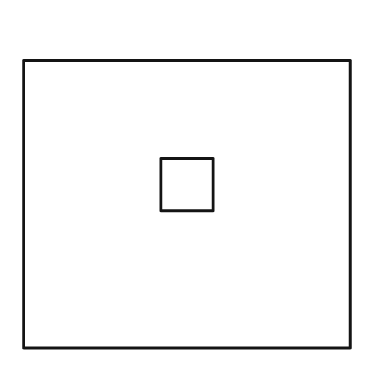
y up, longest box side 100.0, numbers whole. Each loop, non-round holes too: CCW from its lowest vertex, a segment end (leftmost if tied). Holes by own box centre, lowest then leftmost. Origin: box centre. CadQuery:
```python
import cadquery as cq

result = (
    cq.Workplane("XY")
    .moveTo(-50.0, -44.0)
    .lineTo(50.0, -44.0)
    .lineTo(50.0, 44.0)
    .lineTo(-50.0, 44.0)
    .close()
    .moveTo(-8.0, -2.0)
    .lineTo(8.0, -2.0)
    .lineTo(8.0, 14.0)
    .lineTo(-8.0, 14.0)
    .close()
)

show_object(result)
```